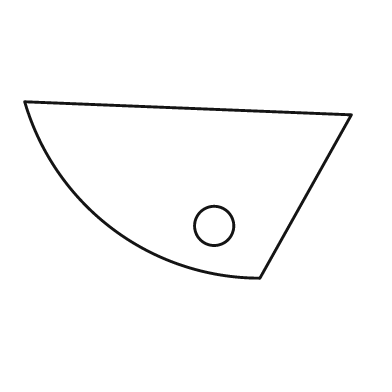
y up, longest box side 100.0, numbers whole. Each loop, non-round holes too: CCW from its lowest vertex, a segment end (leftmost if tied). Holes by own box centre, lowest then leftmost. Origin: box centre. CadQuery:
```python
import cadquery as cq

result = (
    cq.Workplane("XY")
    .moveTo(22.0, -27.0)
    .lineTo(50.0, 23.0)
    .lineTo(-50.0, 27.0)
    .threePointArc((-23.0, -12.0), (22.0, -27.0))
    .close()
    .moveTo(8.0, -11.0)
    .circle(6.0)
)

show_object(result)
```